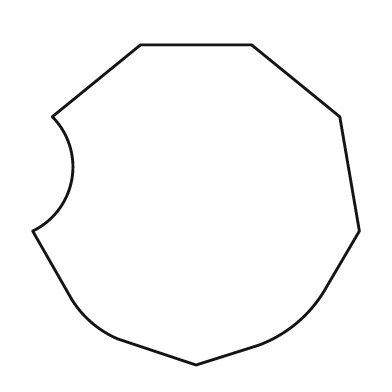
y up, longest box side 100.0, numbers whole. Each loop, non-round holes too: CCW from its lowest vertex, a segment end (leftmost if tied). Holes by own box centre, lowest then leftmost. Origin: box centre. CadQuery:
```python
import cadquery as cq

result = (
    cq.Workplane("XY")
    .moveTo(0.0, -49.0)
    .lineTo(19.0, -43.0)
    .threePointArc((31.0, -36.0), (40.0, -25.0))
    .lineTo(50.0, -8.0)
    .lineTo(44.0, 27.0)
    .lineTo(17.0, 49.0)
    .lineTo(-17.0, 49.0)
    .lineTo(-44.0, 27.0)
    .threePointArc((-38.0, 8.0), (-50.0, -8.0))
    .lineTo(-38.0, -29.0)
    .threePointArc((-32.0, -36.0), (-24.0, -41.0))
    .close()
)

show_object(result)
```